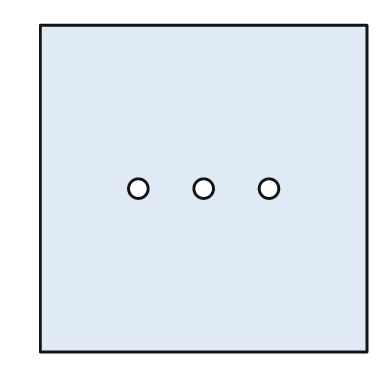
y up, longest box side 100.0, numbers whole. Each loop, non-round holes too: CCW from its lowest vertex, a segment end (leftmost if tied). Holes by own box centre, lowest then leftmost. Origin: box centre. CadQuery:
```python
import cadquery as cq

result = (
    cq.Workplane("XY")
    .moveTo(-50.0, -50.0)
    .lineTo(50.0, -50.0)
    .lineTo(50.0, 50.0)
    .lineTo(-50.0, 50.0)
    .close()
    .moveTo(-20.0, 0.0)
    .circle(3.0)
    .moveTo(0.0, 0.0)
    .circle(3.0)
    .moveTo(20.0, 0.0)
    .circle(3.0)
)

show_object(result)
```